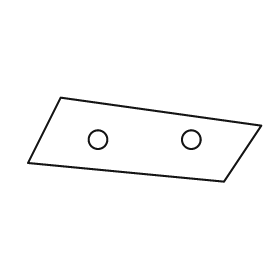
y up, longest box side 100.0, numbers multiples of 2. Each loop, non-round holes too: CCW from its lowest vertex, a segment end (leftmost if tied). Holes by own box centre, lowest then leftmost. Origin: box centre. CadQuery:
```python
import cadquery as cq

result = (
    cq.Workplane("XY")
    .moveTo(34.0, -18.0)
    .lineTo(50.0, 6.0)
    .lineTo(-36.0, 18.0)
    .lineTo(-50.0, -10.0)
    .close()
    .moveTo(-20.0, 0.0)
    .circle(4.0)
    .moveTo(20.0, 0.0)
    .circle(4.0)
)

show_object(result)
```